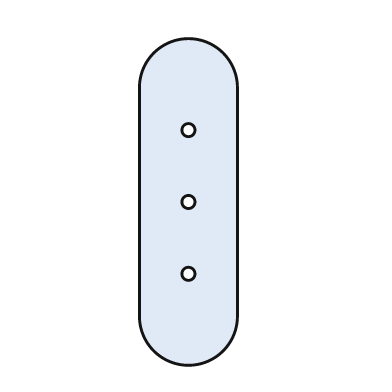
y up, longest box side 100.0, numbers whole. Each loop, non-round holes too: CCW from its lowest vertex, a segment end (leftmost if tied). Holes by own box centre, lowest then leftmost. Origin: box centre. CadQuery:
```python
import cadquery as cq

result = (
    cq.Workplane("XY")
    .moveTo(-15.0, -35.0)
    .threePointArc((0.0, -50.0), (15.0, -35.0))
    .lineTo(15.0, 35.0)
    .threePointArc((0.0, 50.0), (-15.0, 35.0))
    .close()
    .moveTo(0.0, -22.0)
    .circle(2.0)
    .moveTo(0.0, 0.0)
    .circle(2.0)
    .moveTo(0.0, 22.0)
    .circle(2.0)
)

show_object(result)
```